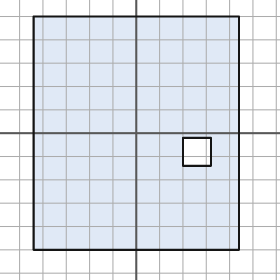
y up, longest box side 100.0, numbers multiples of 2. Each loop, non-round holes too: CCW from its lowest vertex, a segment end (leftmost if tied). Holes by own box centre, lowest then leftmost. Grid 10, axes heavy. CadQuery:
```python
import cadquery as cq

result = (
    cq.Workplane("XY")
    .moveTo(-44.0, -50.0)
    .lineTo(44.0, -50.0)
    .lineTo(44.0, 50.0)
    .lineTo(-44.0, 50.0)
    .close()
    .moveTo(20.0, -14.0)
    .lineTo(32.0, -14.0)
    .lineTo(32.0, -2.0)
    .lineTo(20.0, -2.0)
    .close()
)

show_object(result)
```